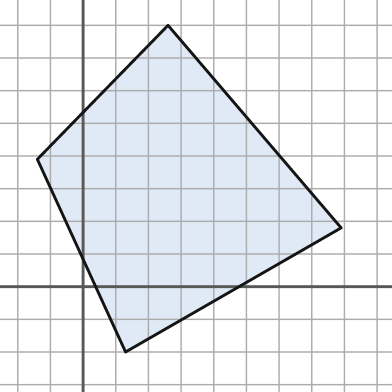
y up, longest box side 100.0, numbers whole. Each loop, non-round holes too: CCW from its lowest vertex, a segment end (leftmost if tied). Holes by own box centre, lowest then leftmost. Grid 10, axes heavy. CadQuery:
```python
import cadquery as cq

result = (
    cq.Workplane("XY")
    .moveTo(13.0, -20.0)
    .lineTo(79.0, 18.0)
    .lineTo(26.0, 80.0)
    .lineTo(-14.0, 39.0)
    .close()
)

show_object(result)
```